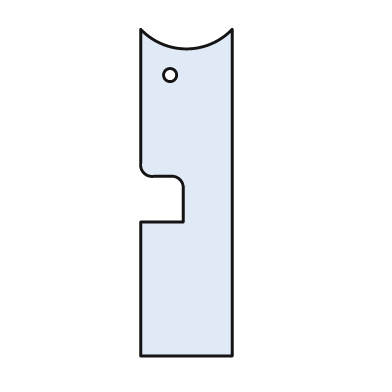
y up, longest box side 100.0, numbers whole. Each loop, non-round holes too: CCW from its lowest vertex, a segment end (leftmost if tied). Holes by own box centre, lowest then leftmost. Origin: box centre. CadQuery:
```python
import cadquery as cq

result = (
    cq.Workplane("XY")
    .moveTo(-14.0, -50.0)
    .lineTo(14.0, -50.0)
    .lineTo(14.0, 50.0)
    .threePointArc((0.0, 44.0), (-14.0, 50.0))
    .lineTo(-14.0, 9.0)
    .threePointArc((-13.0, 6.0), (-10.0, 5.0))
    .lineTo(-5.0, 5.0)
    .threePointArc((-2.0, 4.0), (-1.0, 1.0))
    .lineTo(-1.0, -9.0)
    .lineTo(-14.0, -9.0)
    .close()
    .moveTo(-5.0, 36.0)
    .circle(2.0)
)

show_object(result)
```